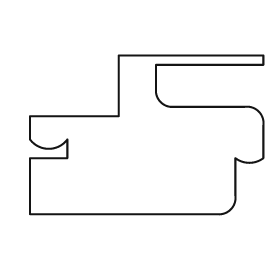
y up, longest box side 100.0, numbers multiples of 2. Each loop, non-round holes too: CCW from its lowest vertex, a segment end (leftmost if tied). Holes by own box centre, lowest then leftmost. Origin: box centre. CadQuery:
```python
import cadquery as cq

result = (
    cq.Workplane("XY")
    .moveTo(-50.0, -34.0)
    .lineTo(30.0, -34.0)
    .threePointArc((36.0, -32.0), (38.0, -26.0))
    .lineTo(38.0, -10.0)
    .threePointArc((44.0, -12.0), (50.0, -10.0))
    .lineTo(50.0, 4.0)
    .threePointArc((48.0, 10.0), (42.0, 12.0))
    .lineTo(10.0, 12.0)
    .threePointArc((6.0, 14.0), (4.0, 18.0))
    .lineTo(4.0, 30.0)
    .lineTo(50.0, 30.0)
    .lineTo(50.0, 34.0)
    .lineTo(-12.0, 34.0)
    .lineTo(-12.0, 8.0)
    .lineTo(-50.0, 8.0)
    .lineTo(-50.0, -2.0)
    .threePointArc((-42.0, -6.0), (-34.0, -2.0))
    .lineTo(-34.0, -10.0)
    .lineTo(-50.0, -10.0)
    .close()
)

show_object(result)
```